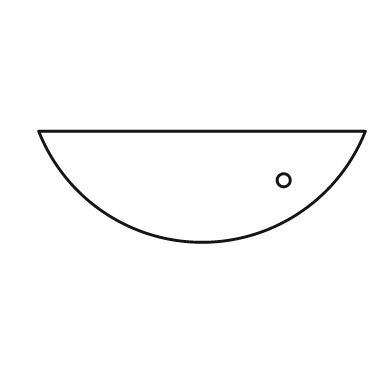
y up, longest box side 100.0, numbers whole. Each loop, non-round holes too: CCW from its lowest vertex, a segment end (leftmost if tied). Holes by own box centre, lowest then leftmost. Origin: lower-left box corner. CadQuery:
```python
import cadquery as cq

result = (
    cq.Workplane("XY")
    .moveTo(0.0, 34.0)
    .threePointArc((50.0, 0.0), (100.0, 34.0))
    .close()
    .moveTo(75.0, 19.0)
    .circle(2.0)
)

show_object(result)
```